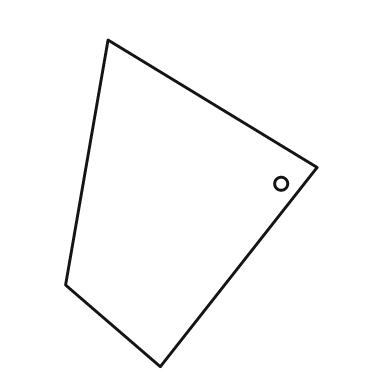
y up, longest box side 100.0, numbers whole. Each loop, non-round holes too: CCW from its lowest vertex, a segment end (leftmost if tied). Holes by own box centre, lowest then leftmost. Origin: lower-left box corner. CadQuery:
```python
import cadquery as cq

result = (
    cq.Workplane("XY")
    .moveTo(29.0, 0.0)
    .lineTo(77.0, 61.0)
    .lineTo(13.0, 100.0)
    .lineTo(0.0, 25.0)
    .close()
    .moveTo(66.0, 56.0)
    .circle(2.0)
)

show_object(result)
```